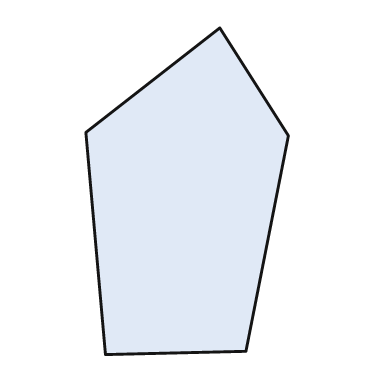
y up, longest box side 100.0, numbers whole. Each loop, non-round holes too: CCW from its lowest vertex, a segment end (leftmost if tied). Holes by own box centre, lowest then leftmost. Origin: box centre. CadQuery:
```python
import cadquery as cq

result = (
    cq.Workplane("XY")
    .moveTo(-25.0, -50.0)
    .lineTo(18.0, -49.0)
    .lineTo(31.0, 17.0)
    .lineTo(10.0, 50.0)
    .lineTo(-31.0, 18.0)
    .close()
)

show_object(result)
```